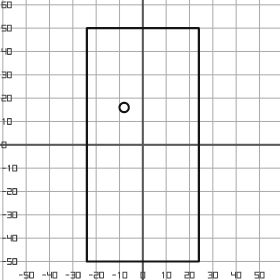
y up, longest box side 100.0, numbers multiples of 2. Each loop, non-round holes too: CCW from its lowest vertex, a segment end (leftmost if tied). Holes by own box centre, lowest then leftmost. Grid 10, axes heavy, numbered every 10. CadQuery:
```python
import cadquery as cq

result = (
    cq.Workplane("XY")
    .moveTo(-24.0, -50.0)
    .lineTo(24.0, -50.0)
    .lineTo(24.0, 50.0)
    .lineTo(-24.0, 50.0)
    .close()
    .moveTo(-8.0, 16.0)
    .circle(2.0)
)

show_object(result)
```